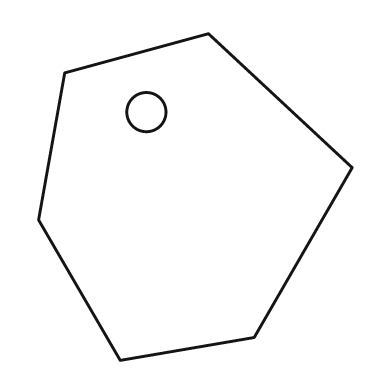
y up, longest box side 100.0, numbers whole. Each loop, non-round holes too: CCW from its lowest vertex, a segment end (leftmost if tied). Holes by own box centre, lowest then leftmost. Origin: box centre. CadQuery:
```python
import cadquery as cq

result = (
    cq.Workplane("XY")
    .moveTo(-23.0, -50.0)
    .lineTo(18.0, -43.0)
    .lineTo(48.0, 9.0)
    .lineTo(4.0, 50.0)
    .lineTo(-40.0, 38.0)
    .lineTo(-48.0, -7.0)
    .close()
    .moveTo(-15.0, 26.0)
    .circle(6.0)
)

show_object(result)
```